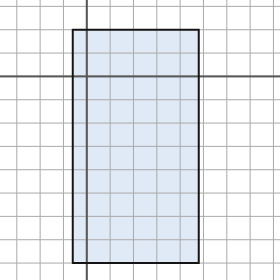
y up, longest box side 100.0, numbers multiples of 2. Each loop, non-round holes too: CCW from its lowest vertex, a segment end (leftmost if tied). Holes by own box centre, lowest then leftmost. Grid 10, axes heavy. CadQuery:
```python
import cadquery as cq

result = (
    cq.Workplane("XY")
    .moveTo(-6.0, -80.0)
    .lineTo(48.0, -80.0)
    .lineTo(48.0, 20.0)
    .lineTo(-6.0, 20.0)
    .close()
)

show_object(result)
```